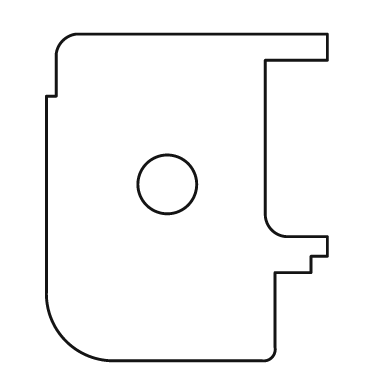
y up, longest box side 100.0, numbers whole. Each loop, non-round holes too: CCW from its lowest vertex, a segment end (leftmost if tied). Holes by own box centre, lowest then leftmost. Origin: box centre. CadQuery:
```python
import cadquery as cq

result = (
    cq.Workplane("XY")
    .moveTo(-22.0, -50.0)
    .lineTo(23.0, -50.0)
    .threePointArc((26.0, -49.0), (27.0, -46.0))
    .lineTo(27.0, -23.0)
    .lineTo(38.0, -23.0)
    .lineTo(38.0, -18.0)
    .lineTo(43.0, -18.0)
    .lineTo(43.0, -12.0)
    .lineTo(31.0, -12.0)
    .threePointArc((26.0, -10.0), (24.0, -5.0))
    .lineTo(24.0, 42.0)
    .lineTo(43.0, 42.0)
    .lineTo(43.0, 50.0)
    .lineTo(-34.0, 50.0)
    .threePointArc((-38.0, 48.0), (-40.0, 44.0))
    .lineTo(-40.0, 31.0)
    .lineTo(-43.0, 31.0)
    .lineTo(-43.0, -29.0)
    .threePointArc((-37.0, -44.0), (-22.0, -50.0))
    .close()
    .moveTo(-6.0, 4.0)
    .circle(9.0)
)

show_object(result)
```